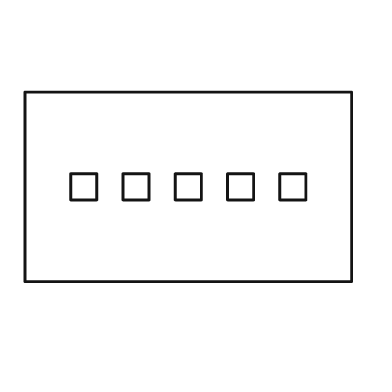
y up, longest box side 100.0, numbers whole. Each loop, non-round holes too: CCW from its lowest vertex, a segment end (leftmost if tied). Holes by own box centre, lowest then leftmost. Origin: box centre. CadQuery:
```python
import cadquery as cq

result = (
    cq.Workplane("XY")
    .moveTo(-50.0, -29.0)
    .lineTo(50.0, -29.0)
    .lineTo(50.0, 29.0)
    .lineTo(-50.0, 29.0)
    .close()
    .moveTo(-36.0, -4.0)
    .lineTo(-28.0, -4.0)
    .lineTo(-28.0, 4.0)
    .lineTo(-36.0, 4.0)
    .close()
    .moveTo(-20.0, -4.0)
    .lineTo(-12.0, -4.0)
    .lineTo(-12.0, 4.0)
    .lineTo(-20.0, 4.0)
    .close()
    .moveTo(-4.0, -4.0)
    .lineTo(4.0, -4.0)
    .lineTo(4.0, 4.0)
    .lineTo(-4.0, 4.0)
    .close()
    .moveTo(12.0, -4.0)
    .lineTo(20.0, -4.0)
    .lineTo(20.0, 4.0)
    .lineTo(12.0, 4.0)
    .close()
    .moveTo(28.0, -4.0)
    .lineTo(36.0, -4.0)
    .lineTo(36.0, 4.0)
    .lineTo(28.0, 4.0)
    .close()
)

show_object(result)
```